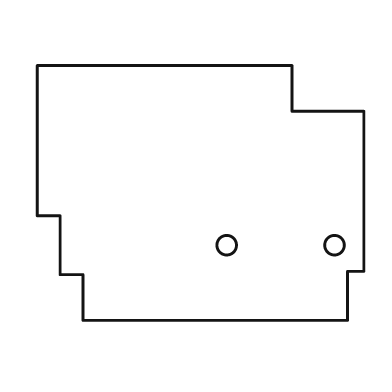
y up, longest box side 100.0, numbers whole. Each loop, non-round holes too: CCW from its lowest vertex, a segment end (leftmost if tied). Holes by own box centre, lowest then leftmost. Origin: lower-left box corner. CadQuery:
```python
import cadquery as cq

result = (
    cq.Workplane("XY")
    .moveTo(14.0, 0.0)
    .lineTo(95.0, 0.0)
    .lineTo(95.0, 15.0)
    .lineTo(100.0, 15.0)
    .lineTo(100.0, 64.0)
    .lineTo(78.0, 64.0)
    .lineTo(78.0, 78.0)
    .lineTo(0.0, 78.0)
    .lineTo(0.0, 32.0)
    .lineTo(7.0, 32.0)
    .lineTo(7.0, 14.0)
    .lineTo(14.0, 14.0)
    .close()
    .moveTo(58.0, 23.0)
    .circle(3.0)
    .moveTo(91.0, 23.0)
    .circle(3.0)
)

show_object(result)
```